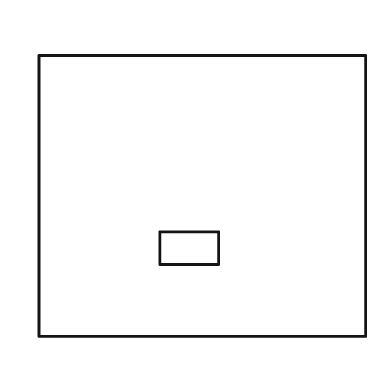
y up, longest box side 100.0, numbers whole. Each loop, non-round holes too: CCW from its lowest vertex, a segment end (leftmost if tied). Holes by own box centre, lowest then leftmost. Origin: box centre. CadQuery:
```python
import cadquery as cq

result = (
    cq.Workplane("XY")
    .moveTo(-50.0, -43.0)
    .lineTo(50.0, -43.0)
    .lineTo(50.0, 43.0)
    .lineTo(-50.0, 43.0)
    .close()
    .moveTo(-13.0, -21.0)
    .lineTo(5.0, -21.0)
    .lineTo(5.0, -11.0)
    .lineTo(-13.0, -11.0)
    .close()
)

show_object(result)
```